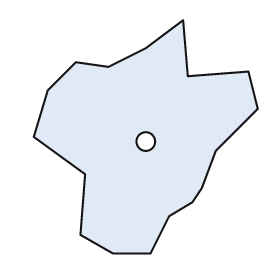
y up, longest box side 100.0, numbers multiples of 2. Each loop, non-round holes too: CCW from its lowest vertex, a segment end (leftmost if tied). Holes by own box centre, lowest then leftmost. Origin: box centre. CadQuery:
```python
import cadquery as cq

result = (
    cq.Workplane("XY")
    .moveTo(-14.0, -50.0)
    .lineTo(2.0, -50.0)
    .lineTo(10.0, -34.0)
    .lineTo(20.0, -28.0)
    .lineTo(24.0, -22.0)
    .lineTo(30.0, -6.0)
    .lineTo(48.0, 12.0)
    .lineTo(44.0, 28.0)
    .lineTo(18.0, 26.0)
    .lineTo(16.0, 50.0)
    .lineTo(0.0, 38.0)
    .lineTo(-16.0, 30.0)
    .lineTo(-30.0, 32.0)
    .lineTo(-42.0, 20.0)
    .lineTo(-48.0, 0.0)
    .lineTo(-26.0, -16.0)
    .lineTo(-28.0, -42.0)
    .close()
    .moveTo(0.0, -2.0)
    .circle(4.0)
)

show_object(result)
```